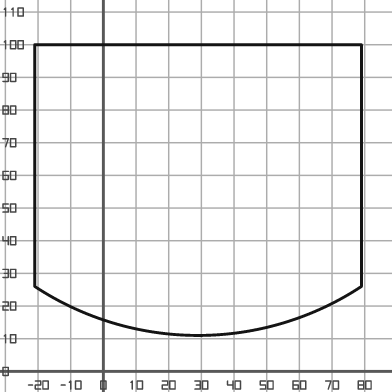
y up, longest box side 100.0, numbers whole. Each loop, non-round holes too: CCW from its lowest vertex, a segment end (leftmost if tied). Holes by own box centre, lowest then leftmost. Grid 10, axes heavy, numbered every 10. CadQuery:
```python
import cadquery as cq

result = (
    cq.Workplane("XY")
    .moveTo(-21.0, 26.0)
    .threePointArc((29.0, 11.0), (79.0, 26.0))
    .lineTo(79.0, 100.0)
    .lineTo(-21.0, 100.0)
    .close()
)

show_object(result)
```